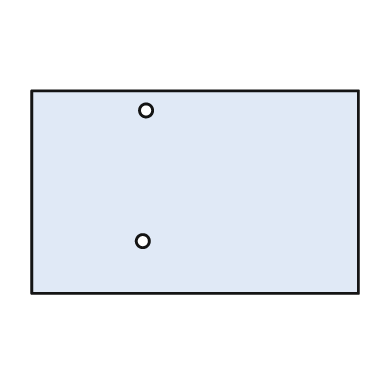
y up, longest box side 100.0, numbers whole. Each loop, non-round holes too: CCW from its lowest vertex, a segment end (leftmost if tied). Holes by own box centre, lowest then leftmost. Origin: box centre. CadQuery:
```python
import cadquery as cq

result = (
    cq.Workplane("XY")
    .moveTo(-50.0, -31.0)
    .lineTo(50.0, -31.0)
    .lineTo(50.0, 31.0)
    .lineTo(-50.0, 31.0)
    .close()
    .moveTo(-16.0, -15.0)
    .circle(2.0)
    .moveTo(-15.0, 25.0)
    .circle(2.0)
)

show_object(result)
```